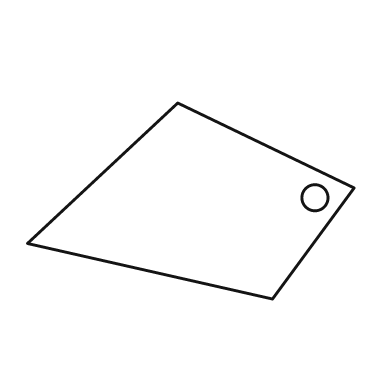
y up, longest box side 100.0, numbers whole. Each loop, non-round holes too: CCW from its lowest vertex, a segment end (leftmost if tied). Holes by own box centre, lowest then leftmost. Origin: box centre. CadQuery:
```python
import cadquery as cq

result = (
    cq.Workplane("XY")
    .moveTo(25.0, -30.0)
    .lineTo(50.0, 4.0)
    .lineTo(-4.0, 30.0)
    .lineTo(-50.0, -13.0)
    .close()
    .moveTo(38.0, 1.0)
    .circle(4.0)
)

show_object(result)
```